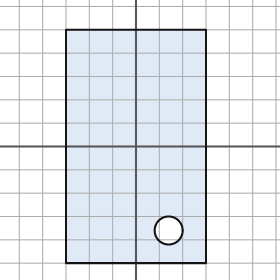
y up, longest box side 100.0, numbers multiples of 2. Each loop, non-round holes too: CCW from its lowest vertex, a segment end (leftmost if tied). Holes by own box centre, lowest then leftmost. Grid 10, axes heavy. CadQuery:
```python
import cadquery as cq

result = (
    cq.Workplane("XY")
    .moveTo(-30.0, -50.0)
    .lineTo(30.0, -50.0)
    .lineTo(30.0, 50.0)
    .lineTo(-30.0, 50.0)
    .close()
    .moveTo(14.0, -36.0)
    .circle(6.0)
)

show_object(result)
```